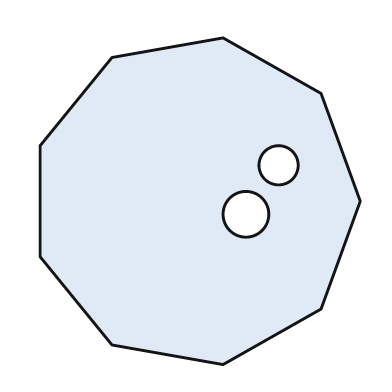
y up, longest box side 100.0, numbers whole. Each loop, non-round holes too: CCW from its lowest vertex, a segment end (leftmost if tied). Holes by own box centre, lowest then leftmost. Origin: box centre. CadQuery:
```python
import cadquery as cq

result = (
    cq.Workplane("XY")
    .moveTo(7.0, -50.0)
    .lineTo(37.0, -33.0)
    .lineTo(49.0, 0.0)
    .lineTo(37.0, 33.0)
    .lineTo(7.0, 50.0)
    .lineTo(-27.0, 44.0)
    .lineTo(-49.0, 17.0)
    .lineTo(-49.0, -17.0)
    .lineTo(-27.0, -44.0)
    .close()
    .moveTo(14.0, -4.0)
    .circle(7.0)
    .moveTo(24.0, 11.0)
    .circle(6.0)
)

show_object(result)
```